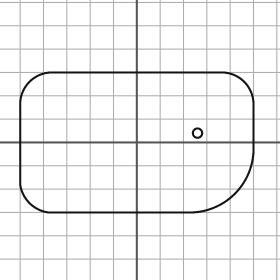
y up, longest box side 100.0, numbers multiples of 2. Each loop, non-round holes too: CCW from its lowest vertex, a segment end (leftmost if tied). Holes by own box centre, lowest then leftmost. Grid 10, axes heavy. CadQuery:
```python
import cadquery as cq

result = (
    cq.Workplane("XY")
    .moveTo(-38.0, -30.0)
    .lineTo(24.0, -30.0)
    .threePointArc((42.0, -22.0), (50.0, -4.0))
    .lineTo(50.0, 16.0)
    .threePointArc((46.0, 26.0), (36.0, 30.0))
    .lineTo(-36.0, 30.0)
    .threePointArc((-46.0, 26.0), (-50.0, 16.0))
    .lineTo(-50.0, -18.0)
    .threePointArc((-46.0, -26.0), (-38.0, -30.0))
    .close()
    .moveTo(26.0, 4.0)
    .circle(2.0)
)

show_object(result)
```